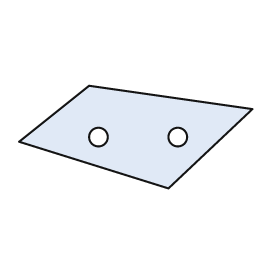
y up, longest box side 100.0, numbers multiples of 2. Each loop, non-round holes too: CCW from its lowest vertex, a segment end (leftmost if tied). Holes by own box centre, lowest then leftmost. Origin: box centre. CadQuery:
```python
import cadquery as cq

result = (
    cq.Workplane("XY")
    .moveTo(14.0, -22.0)
    .lineTo(50.0, 12.0)
    .lineTo(-20.0, 22.0)
    .lineTo(-50.0, -2.0)
    .close()
    .moveTo(-16.0, 0.0)
    .circle(4.0)
    .moveTo(18.0, 0.0)
    .circle(4.0)
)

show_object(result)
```